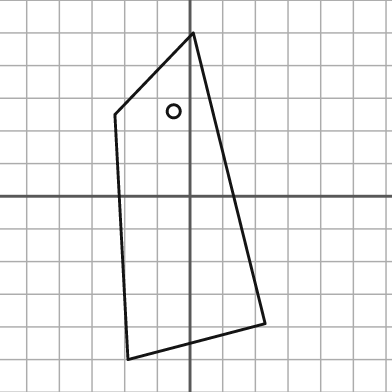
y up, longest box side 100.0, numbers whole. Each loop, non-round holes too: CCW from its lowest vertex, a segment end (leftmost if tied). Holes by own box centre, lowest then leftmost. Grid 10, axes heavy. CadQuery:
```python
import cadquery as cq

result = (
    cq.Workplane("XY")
    .moveTo(-19.0, -50.0)
    .lineTo(23.0, -39.0)
    .lineTo(1.0, 50.0)
    .lineTo(-23.0, 25.0)
    .close()
    .moveTo(-5.0, 26.0)
    .circle(2.0)
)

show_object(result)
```